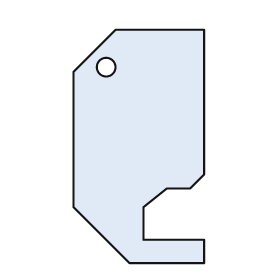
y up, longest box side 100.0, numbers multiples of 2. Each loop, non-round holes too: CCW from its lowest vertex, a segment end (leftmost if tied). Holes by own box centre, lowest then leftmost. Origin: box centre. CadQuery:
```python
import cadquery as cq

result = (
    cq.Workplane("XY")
    .moveTo(-4.0, -50.0)
    .lineTo(28.0, -50.0)
    .lineTo(28.0, -40.0)
    .lineTo(2.0, -40.0)
    .lineTo(2.0, -26.0)
    .lineTo(12.0, -18.0)
    .lineTo(22.0, -18.0)
    .lineTo(28.0, -12.0)
    .lineTo(28.0, 50.0)
    .lineTo(-10.0, 50.0)
    .lineTo(-28.0, 32.0)
    .lineTo(-28.0, -26.0)
    .close()
    .moveTo(-14.0, 34.0)
    .circle(4.0)
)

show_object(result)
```